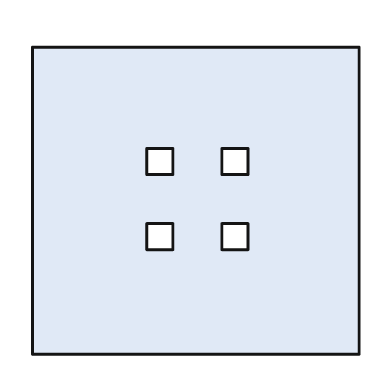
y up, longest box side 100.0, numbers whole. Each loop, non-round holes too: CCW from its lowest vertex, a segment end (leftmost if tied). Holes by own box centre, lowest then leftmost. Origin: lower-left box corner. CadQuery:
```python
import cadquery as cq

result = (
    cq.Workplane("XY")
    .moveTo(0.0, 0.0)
    .lineTo(100.0, 0.0)
    .lineTo(100.0, 94.0)
    .lineTo(0.0, 94.0)
    .close()
    .moveTo(35.0, 32.0)
    .lineTo(43.0, 32.0)
    .lineTo(43.0, 40.0)
    .lineTo(35.0, 40.0)
    .close()
    .moveTo(58.0, 32.0)
    .lineTo(66.0, 32.0)
    .lineTo(66.0, 40.0)
    .lineTo(58.0, 40.0)
    .close()
    .moveTo(35.0, 55.0)
    .lineTo(43.0, 55.0)
    .lineTo(43.0, 63.0)
    .lineTo(35.0, 63.0)
    .close()
    .moveTo(58.0, 55.0)
    .lineTo(66.0, 55.0)
    .lineTo(66.0, 63.0)
    .lineTo(58.0, 63.0)
    .close()
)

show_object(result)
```